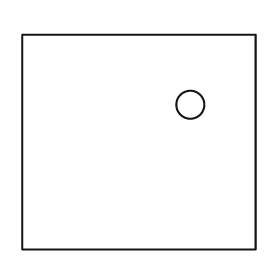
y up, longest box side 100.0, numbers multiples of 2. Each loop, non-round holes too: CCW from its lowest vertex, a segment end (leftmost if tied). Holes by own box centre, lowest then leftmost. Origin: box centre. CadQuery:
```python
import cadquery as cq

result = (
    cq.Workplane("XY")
    .moveTo(-50.0, -46.0)
    .lineTo(50.0, -46.0)
    .lineTo(50.0, 46.0)
    .lineTo(-50.0, 46.0)
    .close()
    .moveTo(22.0, 16.0)
    .circle(6.0)
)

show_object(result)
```